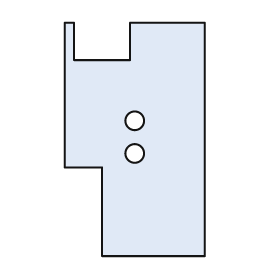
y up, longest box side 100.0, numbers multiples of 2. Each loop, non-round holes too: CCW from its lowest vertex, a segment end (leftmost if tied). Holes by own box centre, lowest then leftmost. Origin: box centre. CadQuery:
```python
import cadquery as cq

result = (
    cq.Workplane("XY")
    .moveTo(-14.0, -50.0)
    .lineTo(30.0, -50.0)
    .lineTo(30.0, 50.0)
    .lineTo(-2.0, 50.0)
    .lineTo(-2.0, 34.0)
    .lineTo(-26.0, 34.0)
    .lineTo(-26.0, 50.0)
    .lineTo(-30.0, 50.0)
    .lineTo(-30.0, -12.0)
    .lineTo(-14.0, -12.0)
    .close()
    .moveTo(0.0, -6.0)
    .circle(4.0)
    .moveTo(0.0, 8.0)
    .circle(4.0)
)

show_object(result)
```